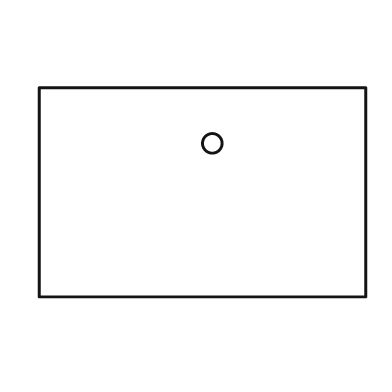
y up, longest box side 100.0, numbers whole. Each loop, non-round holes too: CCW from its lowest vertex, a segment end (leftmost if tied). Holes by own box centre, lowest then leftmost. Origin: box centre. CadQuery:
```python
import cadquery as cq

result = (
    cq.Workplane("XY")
    .moveTo(-50.0, -32.0)
    .lineTo(50.0, -32.0)
    .lineTo(50.0, 32.0)
    .lineTo(-50.0, 32.0)
    .close()
    .moveTo(3.0, 15.0)
    .circle(3.0)
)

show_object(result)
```